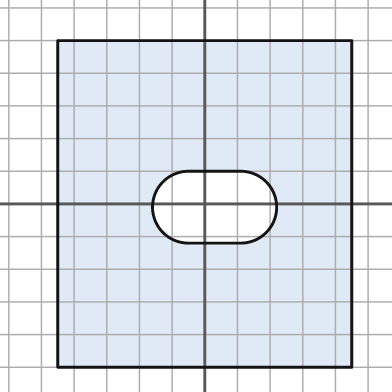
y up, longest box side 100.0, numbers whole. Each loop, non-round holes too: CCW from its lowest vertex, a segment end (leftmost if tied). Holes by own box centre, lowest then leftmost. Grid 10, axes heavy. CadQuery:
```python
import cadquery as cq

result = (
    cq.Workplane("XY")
    .moveTo(-45.0, -50.0)
    .lineTo(45.0, -50.0)
    .lineTo(45.0, 50.0)
    .lineTo(-45.0, 50.0)
    .close()
    .moveTo(-5.0, -12.0)
    .lineTo(11.0, -12.0)
    .threePointArc((22.0, -1.0), (11.0, 10.0))
    .lineTo(-5.0, 10.0)
    .threePointArc((-16.0, -1.0), (-5.0, -12.0))
    .close()
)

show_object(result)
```